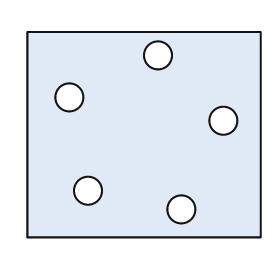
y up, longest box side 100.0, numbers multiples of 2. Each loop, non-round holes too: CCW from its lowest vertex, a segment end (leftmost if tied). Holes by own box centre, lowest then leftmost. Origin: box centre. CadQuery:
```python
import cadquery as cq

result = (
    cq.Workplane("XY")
    .moveTo(-50.0, -44.0)
    .lineTo(50.0, -44.0)
    .lineTo(50.0, 44.0)
    .lineTo(-50.0, 44.0)
    .close()
    .moveTo(16.0, -32.0)
    .circle(6.0)
    .moveTo(-24.0, -24.0)
    .circle(6.0)
    .moveTo(34.0, 6.0)
    .circle(6.0)
    .moveTo(-32.0, 16.0)
    .circle(6.0)
    .moveTo(6.0, 34.0)
    .circle(6.0)
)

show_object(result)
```